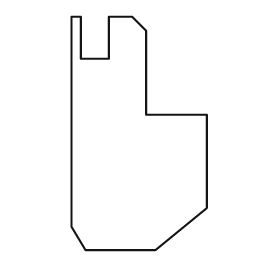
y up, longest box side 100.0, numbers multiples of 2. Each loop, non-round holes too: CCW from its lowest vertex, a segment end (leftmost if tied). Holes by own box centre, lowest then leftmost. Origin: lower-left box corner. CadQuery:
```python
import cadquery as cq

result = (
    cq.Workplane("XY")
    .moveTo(6.0, 0.0)
    .lineTo(36.0, 0.0)
    .lineTo(58.0, 18.0)
    .lineTo(58.0, 58.0)
    .lineTo(32.0, 58.0)
    .lineTo(32.0, 94.0)
    .lineTo(26.0, 100.0)
    .lineTo(16.0, 100.0)
    .lineTo(16.0, 82.0)
    .lineTo(4.0, 82.0)
    .lineTo(4.0, 100.0)
    .lineTo(0.0, 100.0)
    .lineTo(0.0, 10.0)
    .close()
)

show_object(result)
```